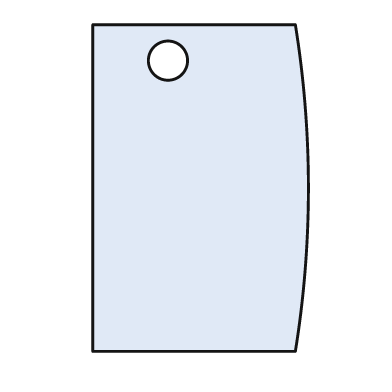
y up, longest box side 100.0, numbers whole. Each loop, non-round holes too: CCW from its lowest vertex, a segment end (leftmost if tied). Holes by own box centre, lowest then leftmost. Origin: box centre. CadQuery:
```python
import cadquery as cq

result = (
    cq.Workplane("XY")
    .moveTo(-33.0, -50.0)
    .lineTo(29.0, -50.0)
    .threePointArc((33.0, 0.0), (29.0, 50.0))
    .lineTo(-33.0, 50.0)
    .close()
    .moveTo(-10.0, 39.0)
    .circle(6.0)
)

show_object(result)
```